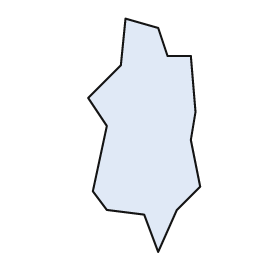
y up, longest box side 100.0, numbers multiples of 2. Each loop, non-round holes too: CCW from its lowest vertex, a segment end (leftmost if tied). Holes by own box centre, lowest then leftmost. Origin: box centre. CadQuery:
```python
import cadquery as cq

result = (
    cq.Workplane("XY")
    .moveTo(6.0, -50.0)
    .lineTo(14.0, -32.0)
    .lineTo(24.0, -22.0)
    .lineTo(20.0, -2.0)
    .lineTo(22.0, 10.0)
    .lineTo(20.0, 34.0)
    .lineTo(10.0, 34.0)
    .lineTo(6.0, 46.0)
    .lineTo(-8.0, 50.0)
    .lineTo(-10.0, 30.0)
    .lineTo(-24.0, 16.0)
    .lineTo(-16.0, 4.0)
    .lineTo(-22.0, -24.0)
    .lineTo(-16.0, -32.0)
    .lineTo(0.0, -34.0)
    .close()
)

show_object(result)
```